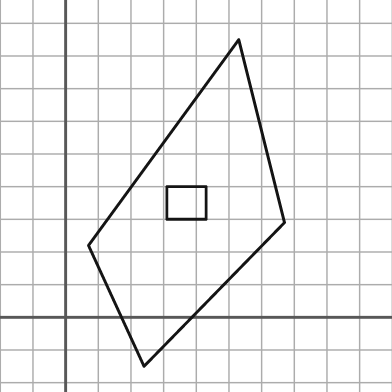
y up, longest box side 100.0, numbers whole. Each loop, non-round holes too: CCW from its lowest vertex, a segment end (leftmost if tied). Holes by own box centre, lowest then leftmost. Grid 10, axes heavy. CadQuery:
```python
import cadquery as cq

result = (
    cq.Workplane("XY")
    .moveTo(24.0, -15.0)
    .lineTo(67.0, 29.0)
    .lineTo(53.0, 85.0)
    .lineTo(7.0, 22.0)
    .close()
    .moveTo(31.0, 30.0)
    .lineTo(43.0, 30.0)
    .lineTo(43.0, 40.0)
    .lineTo(31.0, 40.0)
    .close()
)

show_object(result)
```